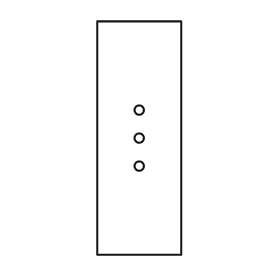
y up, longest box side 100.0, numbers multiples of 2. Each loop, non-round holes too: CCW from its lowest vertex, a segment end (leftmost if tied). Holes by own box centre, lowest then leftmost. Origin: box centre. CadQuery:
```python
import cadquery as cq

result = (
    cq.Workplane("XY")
    .moveTo(-18.0, -50.0)
    .lineTo(18.0, -50.0)
    .lineTo(18.0, 50.0)
    .lineTo(-18.0, 50.0)
    .close()
    .moveTo(0.0, -12.0)
    .circle(2.0)
    .moveTo(0.0, 0.0)
    .circle(2.0)
    .moveTo(0.0, 12.0)
    .circle(2.0)
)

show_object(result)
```